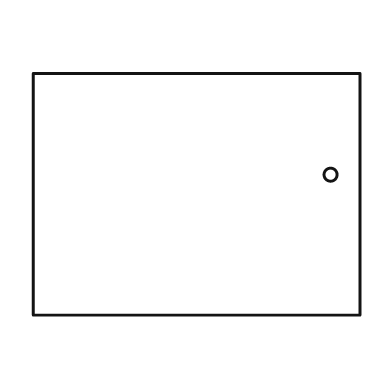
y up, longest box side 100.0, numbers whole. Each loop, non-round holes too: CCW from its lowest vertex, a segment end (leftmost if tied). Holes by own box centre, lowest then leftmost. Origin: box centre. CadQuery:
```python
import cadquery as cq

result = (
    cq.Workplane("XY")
    .moveTo(-50.0, -37.0)
    .lineTo(50.0, -37.0)
    .lineTo(50.0, 37.0)
    .lineTo(-50.0, 37.0)
    .close()
    .moveTo(41.0, 6.0)
    .circle(2.0)
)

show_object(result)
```